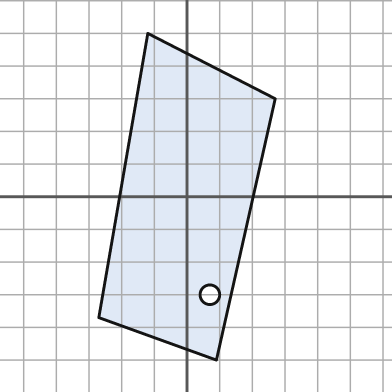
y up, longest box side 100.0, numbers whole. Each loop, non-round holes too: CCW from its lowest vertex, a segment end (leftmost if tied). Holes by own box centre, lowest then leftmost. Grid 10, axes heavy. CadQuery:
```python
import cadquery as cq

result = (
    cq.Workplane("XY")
    .moveTo(9.0, -50.0)
    .lineTo(27.0, 30.0)
    .lineTo(-12.0, 50.0)
    .lineTo(-27.0, -37.0)
    .close()
    .moveTo(7.0, -30.0)
    .circle(3.0)
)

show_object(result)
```